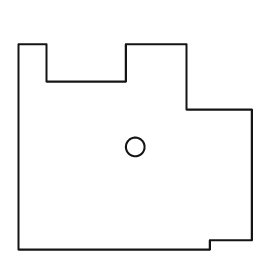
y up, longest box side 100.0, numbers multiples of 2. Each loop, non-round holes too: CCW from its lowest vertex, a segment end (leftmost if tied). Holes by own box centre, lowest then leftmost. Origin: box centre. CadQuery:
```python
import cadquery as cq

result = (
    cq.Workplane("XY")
    .moveTo(-50.0, -44.0)
    .lineTo(32.0, -44.0)
    .lineTo(32.0, -40.0)
    .lineTo(50.0, -40.0)
    .lineTo(50.0, 16.0)
    .lineTo(22.0, 16.0)
    .lineTo(22.0, 44.0)
    .lineTo(-4.0, 44.0)
    .lineTo(-4.0, 28.0)
    .lineTo(-38.0, 28.0)
    .lineTo(-38.0, 44.0)
    .lineTo(-50.0, 44.0)
    .close()
    .moveTo(0.0, 0.0)
    .circle(4.0)
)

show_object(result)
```